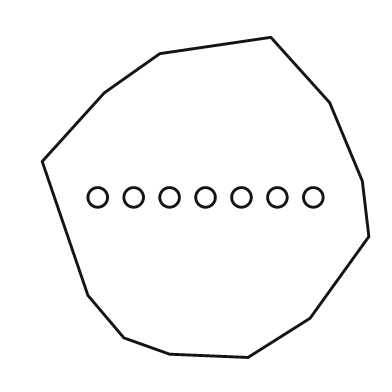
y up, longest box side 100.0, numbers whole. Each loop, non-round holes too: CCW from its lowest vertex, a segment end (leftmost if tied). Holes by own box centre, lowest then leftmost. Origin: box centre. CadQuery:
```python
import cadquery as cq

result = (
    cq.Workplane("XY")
    .moveTo(13.0, -49.0)
    .lineTo(32.0, -37.0)
    .lineTo(50.0, -12.0)
    .lineTo(48.0, 5.0)
    .lineTo(38.0, 29.0)
    .lineTo(20.0, 49.0)
    .lineTo(-14.0, 44.0)
    .lineTo(-31.0, 32.0)
    .lineTo(-50.0, 11.0)
    .lineTo(-36.0, -30.0)
    .lineTo(-25.0, -43.0)
    .lineTo(-11.0, -48.0)
    .close()
    .moveTo(-33.0, 0.0)
    .circle(3.0)
    .moveTo(-22.0, 0.0)
    .circle(3.0)
    .moveTo(-11.0, 0.0)
    .circle(3.0)
    .moveTo(0.0, 0.0)
    .circle(3.0)
    .moveTo(11.0, 0.0)
    .circle(3.0)
    .moveTo(22.0, 0.0)
    .circle(3.0)
    .moveTo(33.0, 0.0)
    .circle(3.0)
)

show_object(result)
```